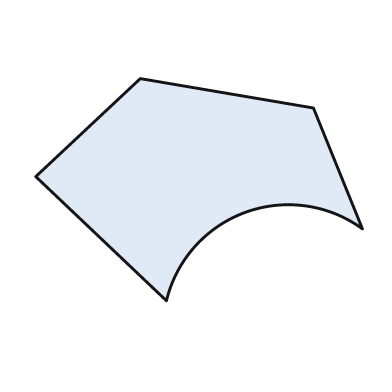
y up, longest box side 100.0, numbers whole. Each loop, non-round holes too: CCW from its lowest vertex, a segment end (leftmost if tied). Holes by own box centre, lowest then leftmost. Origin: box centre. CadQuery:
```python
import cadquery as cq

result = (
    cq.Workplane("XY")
    .moveTo(-10.0, -34.0)
    .threePointArc((14.0, -7.0), (50.0, -12.0))
    .lineTo(35.0, 25.0)
    .lineTo(-18.0, 34.0)
    .lineTo(-50.0, 4.0)
    .close()
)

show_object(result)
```